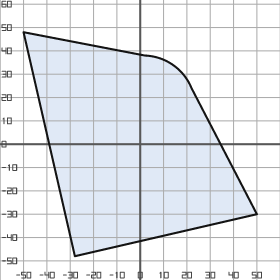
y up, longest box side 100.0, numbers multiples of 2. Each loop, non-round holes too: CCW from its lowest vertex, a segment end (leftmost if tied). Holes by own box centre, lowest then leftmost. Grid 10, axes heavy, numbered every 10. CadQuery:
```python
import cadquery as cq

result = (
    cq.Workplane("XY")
    .moveTo(-28.0, -48.0)
    .lineTo(50.0, -30.0)
    .lineTo(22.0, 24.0)
    .threePointArc((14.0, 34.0), (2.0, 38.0))
    .lineTo(-50.0, 48.0)
    .close()
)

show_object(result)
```